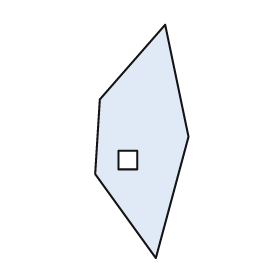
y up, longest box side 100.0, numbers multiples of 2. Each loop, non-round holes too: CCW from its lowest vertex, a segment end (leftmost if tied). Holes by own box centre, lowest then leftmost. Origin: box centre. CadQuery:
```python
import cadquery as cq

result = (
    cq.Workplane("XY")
    .moveTo(6.0, -50.0)
    .lineTo(20.0, 2.0)
    .lineTo(10.0, 50.0)
    .lineTo(-18.0, 18.0)
    .lineTo(-20.0, -14.0)
    .close()
    .moveTo(-10.0, -12.0)
    .lineTo(-2.0, -12.0)
    .lineTo(-2.0, -4.0)
    .lineTo(-10.0, -4.0)
    .close()
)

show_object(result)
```